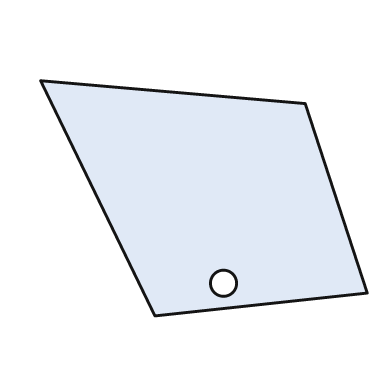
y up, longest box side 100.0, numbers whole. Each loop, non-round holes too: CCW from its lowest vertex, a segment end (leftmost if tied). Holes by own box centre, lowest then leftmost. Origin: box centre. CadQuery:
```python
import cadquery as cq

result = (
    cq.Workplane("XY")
    .moveTo(-15.0, -36.0)
    .lineTo(50.0, -29.0)
    .lineTo(31.0, 29.0)
    .lineTo(-50.0, 36.0)
    .close()
    .moveTo(6.0, -26.0)
    .circle(4.0)
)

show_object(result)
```